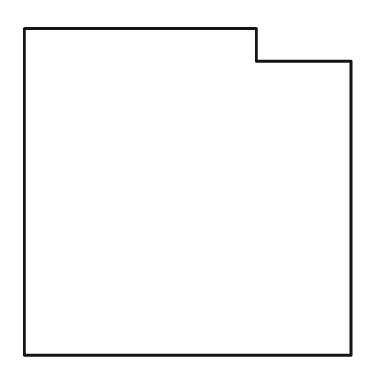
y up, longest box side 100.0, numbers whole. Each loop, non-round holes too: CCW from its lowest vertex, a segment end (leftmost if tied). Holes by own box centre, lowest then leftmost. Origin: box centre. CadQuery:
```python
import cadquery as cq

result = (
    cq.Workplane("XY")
    .moveTo(-50.0, -50.0)
    .lineTo(50.0, -50.0)
    .lineTo(50.0, 40.0)
    .lineTo(21.0, 40.0)
    .lineTo(21.0, 50.0)
    .lineTo(-50.0, 50.0)
    .close()
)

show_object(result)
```